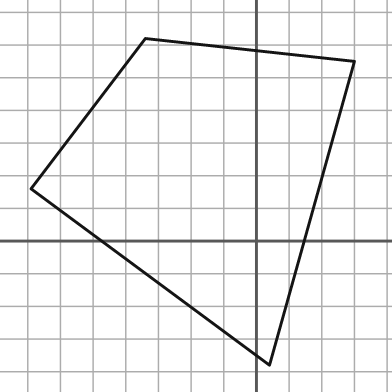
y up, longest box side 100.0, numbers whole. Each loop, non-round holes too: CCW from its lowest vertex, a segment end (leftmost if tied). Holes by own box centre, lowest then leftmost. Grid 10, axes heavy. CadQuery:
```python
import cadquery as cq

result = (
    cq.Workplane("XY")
    .moveTo(4.0, -38.0)
    .lineTo(30.0, 55.0)
    .lineTo(-34.0, 62.0)
    .lineTo(-69.0, 16.0)
    .close()
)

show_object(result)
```